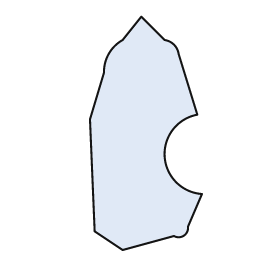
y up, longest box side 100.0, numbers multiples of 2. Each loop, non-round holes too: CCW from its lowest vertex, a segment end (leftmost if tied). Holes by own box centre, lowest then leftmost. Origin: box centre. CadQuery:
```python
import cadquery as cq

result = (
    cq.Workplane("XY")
    .moveTo(-10.0, -50.0)
    .lineTo(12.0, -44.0)
    .threePointArc((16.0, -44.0), (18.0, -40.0))
    .lineTo(24.0, -26.0)
    .threePointArc((8.0, -10.0), (22.0, 8.0))
    .lineTo(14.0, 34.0)
    .threePointArc((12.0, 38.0), (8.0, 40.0))
    .lineTo(-2.0, 50.0)
    .lineTo(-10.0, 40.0)
    .threePointArc((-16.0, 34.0), (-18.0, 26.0))
    .lineTo(-24.0, 6.0)
    .lineTo(-22.0, -42.0)
    .close()
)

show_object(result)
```